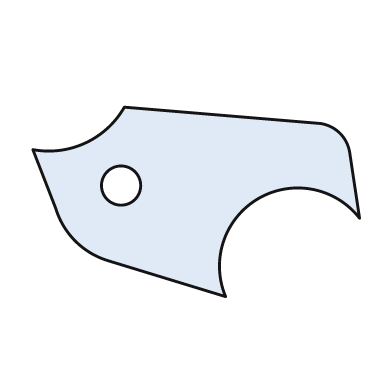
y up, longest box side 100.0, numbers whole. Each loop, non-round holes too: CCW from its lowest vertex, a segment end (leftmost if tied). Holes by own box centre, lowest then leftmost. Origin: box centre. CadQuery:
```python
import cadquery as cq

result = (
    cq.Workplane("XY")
    .moveTo(9.0, -29.0)
    .threePointArc((19.0, 1.0), (50.0, -5.0))
    .lineTo(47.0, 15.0)
    .threePointArc((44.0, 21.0), (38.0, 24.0))
    .lineTo(-22.0, 29.0)
    .threePointArc((-34.0, 18.0), (-50.0, 16.0))
    .lineTo(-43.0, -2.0)
    .threePointArc((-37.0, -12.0), (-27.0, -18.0))
    .close()
    .moveTo(-23.0, 5.0)
    .circle(6.0)
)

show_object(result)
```